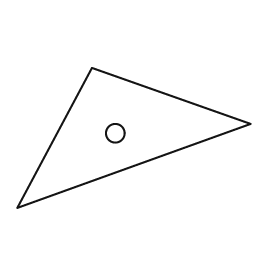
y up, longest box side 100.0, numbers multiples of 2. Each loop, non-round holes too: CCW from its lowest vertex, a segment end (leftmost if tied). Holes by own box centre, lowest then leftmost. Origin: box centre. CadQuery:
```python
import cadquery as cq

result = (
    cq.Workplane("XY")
    .moveTo(-50.0, -30.0)
    .lineTo(50.0, 6.0)
    .lineTo(-18.0, 30.0)
    .close()
    .moveTo(-8.0, 2.0)
    .circle(4.0)
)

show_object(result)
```